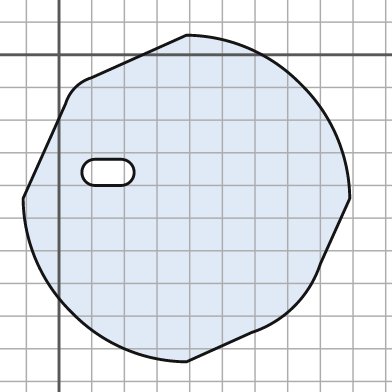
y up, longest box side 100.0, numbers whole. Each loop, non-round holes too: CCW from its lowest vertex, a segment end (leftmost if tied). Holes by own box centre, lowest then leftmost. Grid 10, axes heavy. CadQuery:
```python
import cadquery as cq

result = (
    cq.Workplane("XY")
    .moveTo(39.0, -94.0)
    .lineTo(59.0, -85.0)
    .threePointArc((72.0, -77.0), (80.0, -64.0))
    .lineTo(89.0, -44.0)
    .threePointArc((85.0, -25.0), (74.0, -9.0))
    .threePointArc((58.0, 2.0), (39.0, 6.0))
    .lineTo(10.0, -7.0)
    .threePointArc((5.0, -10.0), (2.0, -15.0))
    .lineTo(-11.0, -44.0)
    .threePointArc((-7.0, -63.0), (4.0, -79.0))
    .threePointArc((20.0, -90.0), (39.0, -94.0))
    .close()
    .moveTo(11.0, -40.0)
    .lineTo(19.0, -40.0)
    .threePointArc((23.0, -36.0), (19.0, -32.0))
    .lineTo(11.0, -32.0)
    .threePointArc((7.0, -36.0), (11.0, -40.0))
    .close()
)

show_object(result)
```